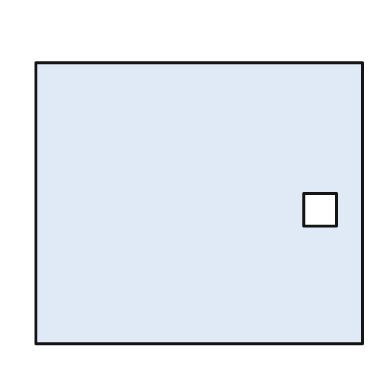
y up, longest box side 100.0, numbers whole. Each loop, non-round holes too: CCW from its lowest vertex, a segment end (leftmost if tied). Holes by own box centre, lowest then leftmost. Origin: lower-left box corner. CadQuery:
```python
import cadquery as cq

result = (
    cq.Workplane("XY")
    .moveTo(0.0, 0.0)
    .lineTo(100.0, 0.0)
    .lineTo(100.0, 86.0)
    .lineTo(0.0, 86.0)
    .close()
    .moveTo(82.0, 36.0)
    .lineTo(92.0, 36.0)
    .lineTo(92.0, 46.0)
    .lineTo(82.0, 46.0)
    .close()
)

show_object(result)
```